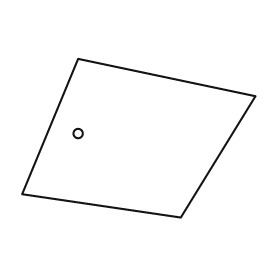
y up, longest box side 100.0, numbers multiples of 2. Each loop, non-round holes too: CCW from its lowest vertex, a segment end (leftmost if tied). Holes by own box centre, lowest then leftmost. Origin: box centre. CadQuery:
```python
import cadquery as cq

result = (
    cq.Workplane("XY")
    .moveTo(18.0, -34.0)
    .lineTo(50.0, 18.0)
    .lineTo(-26.0, 34.0)
    .lineTo(-50.0, -24.0)
    .close()
    .moveTo(-26.0, 2.0)
    .circle(2.0)
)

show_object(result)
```